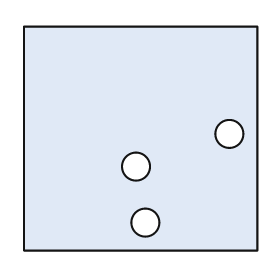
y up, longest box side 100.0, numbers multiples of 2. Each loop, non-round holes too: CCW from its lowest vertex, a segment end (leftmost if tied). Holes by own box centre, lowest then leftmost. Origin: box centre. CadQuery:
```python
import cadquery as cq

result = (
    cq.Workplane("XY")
    .moveTo(-50.0, -48.0)
    .lineTo(50.0, -48.0)
    .lineTo(50.0, 48.0)
    .lineTo(-50.0, 48.0)
    .close()
    .moveTo(2.0, -36.0)
    .circle(6.0)
    .moveTo(-2.0, -12.0)
    .circle(6.0)
    .moveTo(38.0, 2.0)
    .circle(6.0)
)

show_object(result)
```